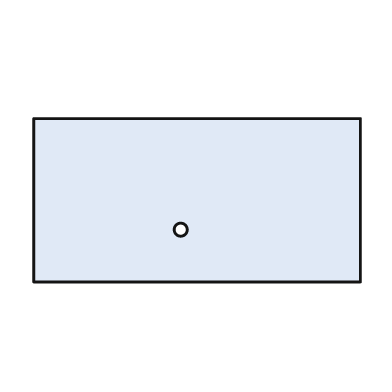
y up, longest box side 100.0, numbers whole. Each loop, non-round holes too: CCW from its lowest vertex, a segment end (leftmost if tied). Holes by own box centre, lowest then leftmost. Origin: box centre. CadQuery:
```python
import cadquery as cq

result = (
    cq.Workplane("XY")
    .moveTo(-50.0, -25.0)
    .lineTo(50.0, -25.0)
    .lineTo(50.0, 25.0)
    .lineTo(-50.0, 25.0)
    .close()
    .moveTo(-5.0, -9.0)
    .circle(2.0)
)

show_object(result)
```